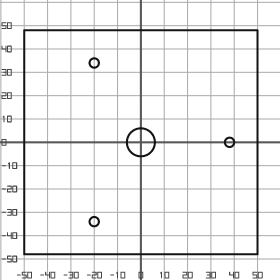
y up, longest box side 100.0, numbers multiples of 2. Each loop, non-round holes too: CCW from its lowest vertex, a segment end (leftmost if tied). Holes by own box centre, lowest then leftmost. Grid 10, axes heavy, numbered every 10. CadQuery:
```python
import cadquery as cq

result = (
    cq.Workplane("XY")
    .moveTo(-50.0, -48.0)
    .lineTo(50.0, -48.0)
    .lineTo(50.0, 48.0)
    .lineTo(-50.0, 48.0)
    .close()
    .moveTo(-20.0, -34.0)
    .circle(2.0)
    .moveTo(0.0, 0.0)
    .circle(6.0)
    .moveTo(38.0, 0.0)
    .circle(2.0)
    .moveTo(-20.0, 34.0)
    .circle(2.0)
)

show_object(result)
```